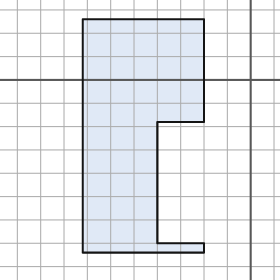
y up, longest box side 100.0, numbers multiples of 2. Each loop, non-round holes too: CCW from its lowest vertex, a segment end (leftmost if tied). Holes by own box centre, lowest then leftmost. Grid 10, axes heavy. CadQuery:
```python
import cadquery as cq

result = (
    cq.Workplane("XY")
    .moveTo(-72.0, -74.0)
    .lineTo(-20.0, -74.0)
    .lineTo(-20.0, -70.0)
    .lineTo(-40.0, -70.0)
    .lineTo(-40.0, -18.0)
    .lineTo(-20.0, -18.0)
    .lineTo(-20.0, 26.0)
    .lineTo(-72.0, 26.0)
    .close()
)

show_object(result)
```